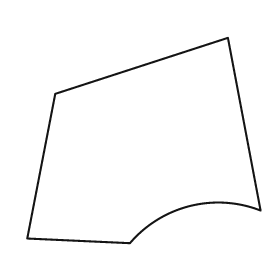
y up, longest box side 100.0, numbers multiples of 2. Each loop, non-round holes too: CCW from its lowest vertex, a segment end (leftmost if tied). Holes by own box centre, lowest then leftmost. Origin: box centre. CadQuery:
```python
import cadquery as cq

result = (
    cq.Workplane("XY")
    .moveTo(-6.0, -44.0)
    .threePointArc((20.0, -28.0), (50.0, -30.0))
    .lineTo(36.0, 44.0)
    .lineTo(-38.0, 20.0)
    .lineTo(-50.0, -42.0)
    .close()
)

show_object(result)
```